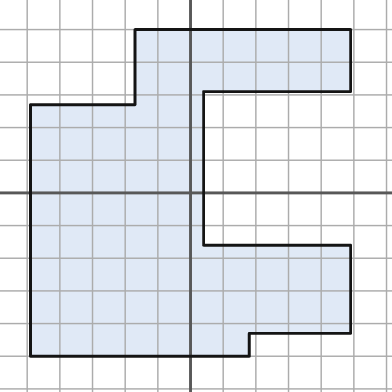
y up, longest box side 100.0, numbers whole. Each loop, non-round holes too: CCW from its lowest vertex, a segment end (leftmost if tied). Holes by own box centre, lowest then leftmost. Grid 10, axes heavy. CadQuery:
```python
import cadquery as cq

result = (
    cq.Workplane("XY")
    .moveTo(-49.0, -50.0)
    .lineTo(18.0, -50.0)
    .lineTo(18.0, -43.0)
    .lineTo(49.0, -43.0)
    .lineTo(49.0, -16.0)
    .lineTo(4.0, -16.0)
    .lineTo(4.0, 31.0)
    .lineTo(49.0, 31.0)
    .lineTo(49.0, 50.0)
    .lineTo(-17.0, 50.0)
    .lineTo(-17.0, 27.0)
    .lineTo(-49.0, 27.0)
    .close()
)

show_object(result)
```